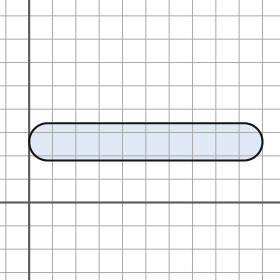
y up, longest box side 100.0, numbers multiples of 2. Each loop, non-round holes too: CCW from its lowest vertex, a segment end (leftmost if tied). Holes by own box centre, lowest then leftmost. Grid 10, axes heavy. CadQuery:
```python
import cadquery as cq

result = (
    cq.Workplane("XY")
    .moveTo(8.0, 18.0)
    .lineTo(92.0, 18.0)
    .threePointArc((100.0, 26.0), (92.0, 34.0))
    .lineTo(8.0, 34.0)
    .threePointArc((0.0, 26.0), (8.0, 18.0))
    .close()
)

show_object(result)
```